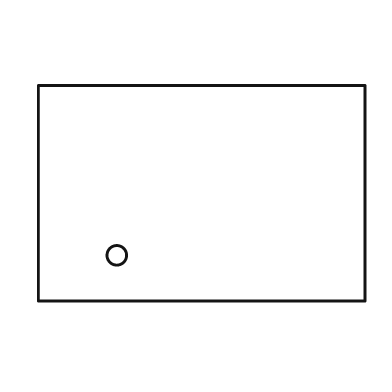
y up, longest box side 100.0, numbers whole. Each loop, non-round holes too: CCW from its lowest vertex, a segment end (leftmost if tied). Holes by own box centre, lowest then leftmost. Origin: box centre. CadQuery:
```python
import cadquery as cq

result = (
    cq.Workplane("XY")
    .moveTo(-50.0, -33.0)
    .lineTo(50.0, -33.0)
    .lineTo(50.0, 33.0)
    .lineTo(-50.0, 33.0)
    .close()
    .moveTo(-26.0, -19.0)
    .circle(3.0)
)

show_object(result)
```